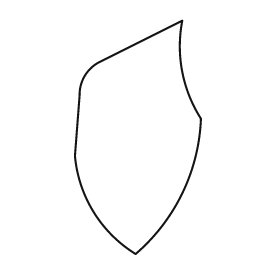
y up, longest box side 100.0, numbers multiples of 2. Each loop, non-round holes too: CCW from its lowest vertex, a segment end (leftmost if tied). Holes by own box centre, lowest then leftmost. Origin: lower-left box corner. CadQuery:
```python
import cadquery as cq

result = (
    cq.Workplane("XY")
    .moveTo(26.0, 0.0)
    .threePointArc((46.0, 26.0), (54.0, 58.0))
    .threePointArc((46.0, 78.0), (46.0, 100.0))
    .lineTo(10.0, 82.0)
    .threePointArc((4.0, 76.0), (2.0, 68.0))
    .lineTo(0.0, 42.0)
    .threePointArc((8.0, 18.0), (26.0, 0.0))
    .close()
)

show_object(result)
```